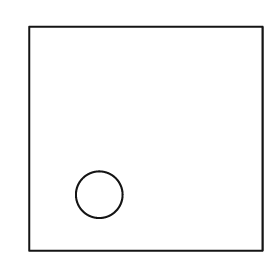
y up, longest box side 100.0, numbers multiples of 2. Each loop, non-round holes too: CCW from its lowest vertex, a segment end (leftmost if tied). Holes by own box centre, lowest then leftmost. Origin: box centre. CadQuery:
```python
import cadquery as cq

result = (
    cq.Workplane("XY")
    .moveTo(-50.0, -48.0)
    .lineTo(50.0, -48.0)
    .lineTo(50.0, 48.0)
    .lineTo(-50.0, 48.0)
    .close()
    .moveTo(-20.0, -24.0)
    .circle(10.0)
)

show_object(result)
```